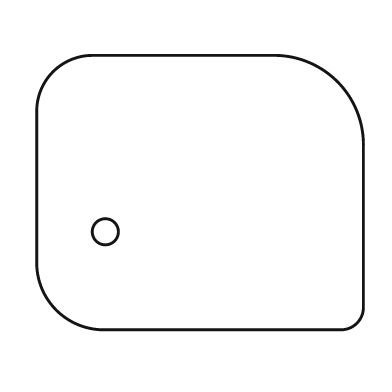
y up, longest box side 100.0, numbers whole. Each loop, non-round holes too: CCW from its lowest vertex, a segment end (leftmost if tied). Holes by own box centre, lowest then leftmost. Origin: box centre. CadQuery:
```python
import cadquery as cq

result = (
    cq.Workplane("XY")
    .moveTo(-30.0, -42.0)
    .lineTo(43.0, -42.0)
    .threePointArc((48.0, -40.0), (50.0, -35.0))
    .lineTo(50.0, 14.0)
    .threePointArc((42.0, 34.0), (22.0, 42.0))
    .lineTo(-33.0, 42.0)
    .threePointArc((-45.0, 37.0), (-50.0, 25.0))
    .lineTo(-50.0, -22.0)
    .threePointArc((-44.0, -36.0), (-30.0, -42.0))
    .close()
    .moveTo(-29.0, -12.0)
    .circle(4.0)
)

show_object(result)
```